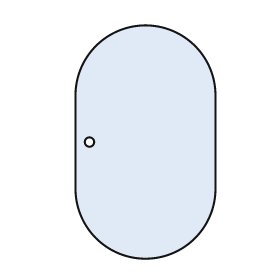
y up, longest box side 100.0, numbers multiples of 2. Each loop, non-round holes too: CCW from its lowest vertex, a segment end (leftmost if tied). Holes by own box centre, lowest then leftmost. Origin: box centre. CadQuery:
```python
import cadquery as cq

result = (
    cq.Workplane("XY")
    .moveTo(-30.0, -20.0)
    .threePointArc((0.0, -50.0), (30.0, -20.0))
    .lineTo(30.0, 20.0)
    .threePointArc((0.0, 50.0), (-30.0, 20.0))
    .close()
    .moveTo(-24.0, 0.0)
    .circle(2.0)
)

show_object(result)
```